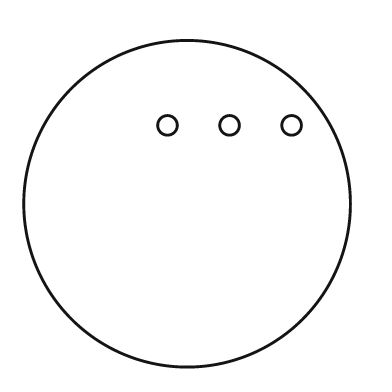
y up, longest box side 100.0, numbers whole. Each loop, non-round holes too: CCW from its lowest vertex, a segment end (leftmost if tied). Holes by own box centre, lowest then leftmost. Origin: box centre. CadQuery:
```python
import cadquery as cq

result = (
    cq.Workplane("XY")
    .moveTo(0.0, 0.0)
    .circle(50.0)
    .moveTo(-6.0, 24.0)
    .circle(3.0)
    .moveTo(13.0, 24.0)
    .circle(3.0)
    .moveTo(32.0, 24.0)
    .circle(3.0)
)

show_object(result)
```